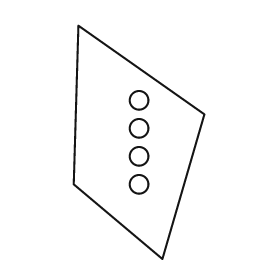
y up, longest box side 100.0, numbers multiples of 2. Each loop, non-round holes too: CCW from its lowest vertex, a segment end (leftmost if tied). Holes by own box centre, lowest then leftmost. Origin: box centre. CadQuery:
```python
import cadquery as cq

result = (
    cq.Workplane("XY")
    .moveTo(10.0, -50.0)
    .lineTo(28.0, 12.0)
    .lineTo(-26.0, 50.0)
    .lineTo(-28.0, -18.0)
    .close()
    .moveTo(0.0, -18.0)
    .circle(4.0)
    .moveTo(0.0, -6.0)
    .circle(4.0)
    .moveTo(0.0, 6.0)
    .circle(4.0)
    .moveTo(0.0, 18.0)
    .circle(4.0)
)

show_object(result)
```